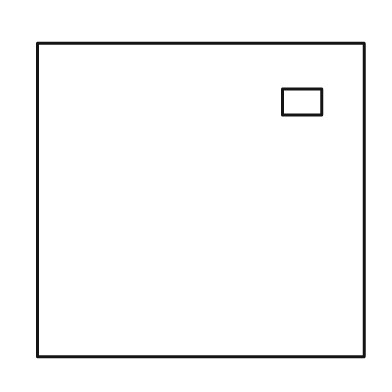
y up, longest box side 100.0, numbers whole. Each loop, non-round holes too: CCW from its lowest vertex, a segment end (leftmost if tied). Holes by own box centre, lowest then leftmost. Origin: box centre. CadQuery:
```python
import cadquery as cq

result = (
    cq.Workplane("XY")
    .moveTo(-50.0, -48.0)
    .lineTo(50.0, -48.0)
    .lineTo(50.0, 48.0)
    .lineTo(-50.0, 48.0)
    .close()
    .moveTo(25.0, 26.0)
    .lineTo(37.0, 26.0)
    .lineTo(37.0, 34.0)
    .lineTo(25.0, 34.0)
    .close()
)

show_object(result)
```